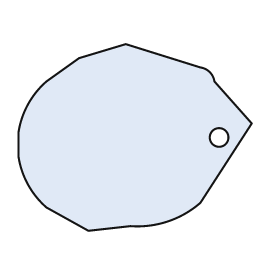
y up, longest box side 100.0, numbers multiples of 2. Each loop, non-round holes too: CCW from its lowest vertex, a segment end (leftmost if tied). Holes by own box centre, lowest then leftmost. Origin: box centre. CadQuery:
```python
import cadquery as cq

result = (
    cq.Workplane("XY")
    .moveTo(-20.0, -40.0)
    .lineTo(-2.0, -38.0)
    .threePointArc((14.0, -36.0), (28.0, -28.0))
    .lineTo(50.0, 6.0)
    .lineTo(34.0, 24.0)
    .threePointArc((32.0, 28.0), (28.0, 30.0))
    .lineTo(-4.0, 40.0)
    .lineTo(-24.0, 34.0)
    .lineTo(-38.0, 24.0)
    .threePointArc((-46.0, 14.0), (-50.0, 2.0))
    .lineTo(-50.0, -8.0)
    .threePointArc((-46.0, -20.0), (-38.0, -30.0))
    .close()
    .moveTo(36.0, 0.0)
    .circle(4.0)
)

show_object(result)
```